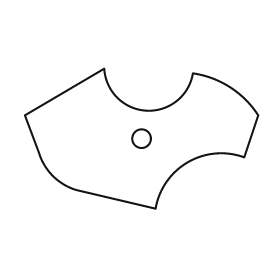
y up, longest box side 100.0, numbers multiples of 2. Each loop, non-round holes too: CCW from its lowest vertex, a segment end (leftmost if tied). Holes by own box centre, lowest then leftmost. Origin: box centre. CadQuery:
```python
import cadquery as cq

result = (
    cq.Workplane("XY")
    .moveTo(6.0, -30.0)
    .threePointArc((20.0, -10.0), (44.0, -8.0))
    .lineTo(50.0, 10.0)
    .threePointArc((38.0, 22.0), (22.0, 28.0))
    .threePointArc((2.0, 12.0), (-16.0, 30.0))
    .lineTo(-50.0, 10.0)
    .lineTo(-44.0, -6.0)
    .threePointArc((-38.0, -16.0), (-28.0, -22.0))
    .close()
    .moveTo(0.0, 0.0)
    .circle(4.0)
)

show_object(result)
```